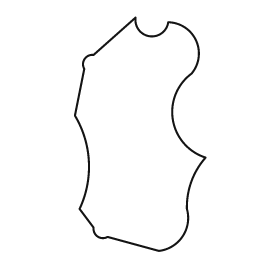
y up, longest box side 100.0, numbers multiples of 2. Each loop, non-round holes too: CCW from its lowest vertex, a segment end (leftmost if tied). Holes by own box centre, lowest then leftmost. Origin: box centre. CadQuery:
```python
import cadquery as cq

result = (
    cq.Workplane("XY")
    .moveTo(8.0, -50.0)
    .threePointArc((18.0, -44.0), (20.0, -32.0))
    .threePointArc((22.0, -20.0), (28.0, -10.0))
    .threePointArc((14.0, 6.0), (22.0, 26.0))
    .threePointArc((24.0, 40.0), (12.0, 48.0))
    .threePointArc((4.0, 42.0), (-2.0, 50.0))
    .lineTo(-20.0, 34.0)
    .threePointArc((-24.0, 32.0), (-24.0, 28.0))
    .lineTo(-28.0, 8.0)
    .threePointArc((-22.0, -12.0), (-26.0, -32.0))
    .lineTo(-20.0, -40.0)
    .threePointArc((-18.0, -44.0), (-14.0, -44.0))
    .close()
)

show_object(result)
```